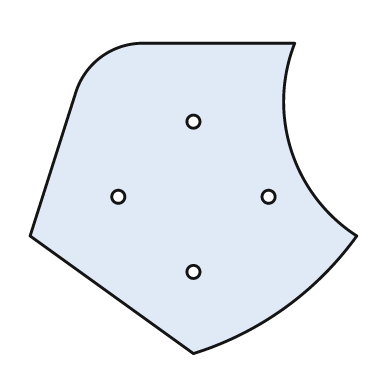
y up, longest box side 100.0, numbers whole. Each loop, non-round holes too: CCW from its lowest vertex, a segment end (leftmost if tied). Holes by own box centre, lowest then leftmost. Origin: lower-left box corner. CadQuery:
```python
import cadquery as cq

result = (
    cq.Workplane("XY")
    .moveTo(50.0, 0.0)
    .threePointArc((78.0, 14.0), (100.0, 36.0))
    .threePointArc((80.0, 62.0), (81.0, 95.0))
    .lineTo(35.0, 95.0)
    .threePointArc((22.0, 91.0), (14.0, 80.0))
    .lineTo(0.0, 36.0)
    .close()
    .moveTo(50.0, 25.0)
    .circle(2.0)
    .moveTo(27.0, 48.0)
    .circle(2.0)
    .moveTo(73.0, 48.0)
    .circle(2.0)
    .moveTo(50.0, 71.0)
    .circle(2.0)
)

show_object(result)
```